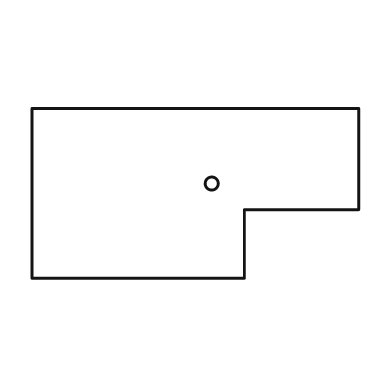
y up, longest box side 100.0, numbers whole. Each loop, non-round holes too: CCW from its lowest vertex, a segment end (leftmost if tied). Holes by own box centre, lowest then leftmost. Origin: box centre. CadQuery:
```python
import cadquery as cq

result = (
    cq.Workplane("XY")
    .moveTo(-50.0, -26.0)
    .lineTo(15.0, -26.0)
    .lineTo(15.0, -5.0)
    .lineTo(50.0, -5.0)
    .lineTo(50.0, 26.0)
    .lineTo(-50.0, 26.0)
    .close()
    .moveTo(5.0, 3.0)
    .circle(2.0)
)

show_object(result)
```